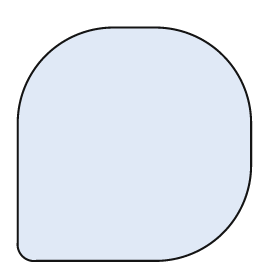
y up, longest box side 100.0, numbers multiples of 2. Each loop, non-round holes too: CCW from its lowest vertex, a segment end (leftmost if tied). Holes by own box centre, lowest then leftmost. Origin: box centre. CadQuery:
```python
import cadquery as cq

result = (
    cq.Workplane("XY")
    .moveTo(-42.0, -50.0)
    .lineTo(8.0, -50.0)
    .threePointArc((38.0, -38.0), (50.0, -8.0))
    .lineTo(50.0, 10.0)
    .threePointArc((38.0, 38.0), (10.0, 50.0))
    .lineTo(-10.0, 50.0)
    .threePointArc((-38.0, 38.0), (-50.0, 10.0))
    .lineTo(-50.0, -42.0)
    .threePointArc((-48.0, -48.0), (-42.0, -50.0))
    .close()
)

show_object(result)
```